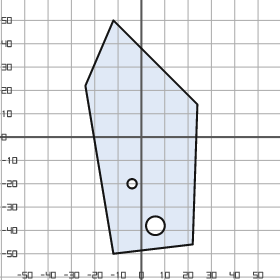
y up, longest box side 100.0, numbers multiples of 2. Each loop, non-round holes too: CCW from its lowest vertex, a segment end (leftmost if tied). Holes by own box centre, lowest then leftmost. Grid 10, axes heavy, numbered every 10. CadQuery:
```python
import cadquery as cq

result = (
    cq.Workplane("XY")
    .moveTo(-12.0, -50.0)
    .lineTo(22.0, -46.0)
    .lineTo(24.0, 14.0)
    .lineTo(-12.0, 50.0)
    .lineTo(-24.0, 22.0)
    .close()
    .moveTo(6.0, -38.0)
    .circle(4.0)
    .moveTo(-4.0, -20.0)
    .circle(2.0)
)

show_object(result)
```